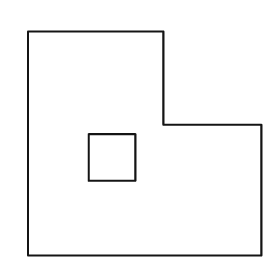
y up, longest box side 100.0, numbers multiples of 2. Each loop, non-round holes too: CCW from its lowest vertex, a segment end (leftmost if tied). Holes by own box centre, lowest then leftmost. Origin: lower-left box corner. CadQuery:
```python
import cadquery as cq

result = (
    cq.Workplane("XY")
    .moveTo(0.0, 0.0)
    .lineTo(100.0, 0.0)
    .lineTo(100.0, 56.0)
    .lineTo(58.0, 56.0)
    .lineTo(58.0, 96.0)
    .lineTo(0.0, 96.0)
    .close()
    .moveTo(26.0, 32.0)
    .lineTo(46.0, 32.0)
    .lineTo(46.0, 52.0)
    .lineTo(26.0, 52.0)
    .close()
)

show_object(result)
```